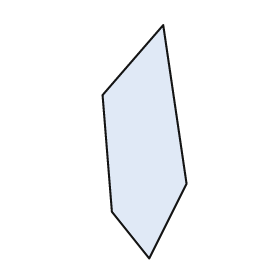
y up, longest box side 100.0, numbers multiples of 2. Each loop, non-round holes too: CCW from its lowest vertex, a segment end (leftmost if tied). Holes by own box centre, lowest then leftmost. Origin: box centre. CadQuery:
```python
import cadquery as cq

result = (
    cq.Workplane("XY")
    .moveTo(2.0, -50.0)
    .lineTo(18.0, -18.0)
    .lineTo(8.0, 50.0)
    .lineTo(-18.0, 20.0)
    .lineTo(-14.0, -30.0)
    .close()
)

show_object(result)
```